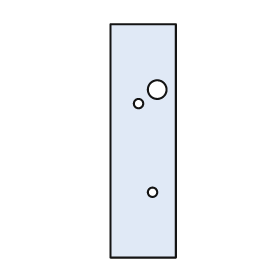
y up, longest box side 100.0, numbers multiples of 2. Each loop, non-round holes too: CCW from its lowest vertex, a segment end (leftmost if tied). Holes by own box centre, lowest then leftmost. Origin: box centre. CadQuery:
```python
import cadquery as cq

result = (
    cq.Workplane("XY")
    .moveTo(-14.0, -50.0)
    .lineTo(14.0, -50.0)
    .lineTo(14.0, 50.0)
    .lineTo(-14.0, 50.0)
    .close()
    .moveTo(4.0, -22.0)
    .circle(2.0)
    .moveTo(-2.0, 16.0)
    .circle(2.0)
    .moveTo(6.0, 22.0)
    .circle(4.0)
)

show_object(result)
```